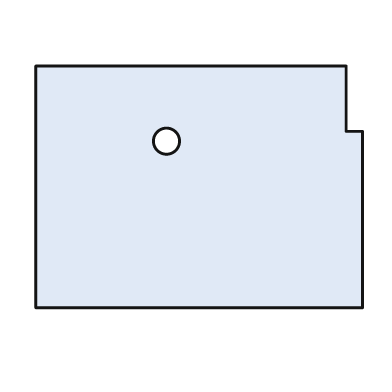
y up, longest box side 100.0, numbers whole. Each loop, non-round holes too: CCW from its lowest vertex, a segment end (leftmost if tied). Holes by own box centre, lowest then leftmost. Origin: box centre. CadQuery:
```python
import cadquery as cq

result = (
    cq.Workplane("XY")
    .moveTo(-50.0, -37.0)
    .lineTo(50.0, -37.0)
    .lineTo(50.0, 17.0)
    .lineTo(45.0, 17.0)
    .lineTo(45.0, 37.0)
    .lineTo(-50.0, 37.0)
    .close()
    .moveTo(-10.0, 14.0)
    .circle(4.0)
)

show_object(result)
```